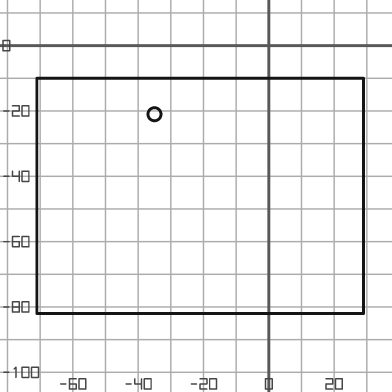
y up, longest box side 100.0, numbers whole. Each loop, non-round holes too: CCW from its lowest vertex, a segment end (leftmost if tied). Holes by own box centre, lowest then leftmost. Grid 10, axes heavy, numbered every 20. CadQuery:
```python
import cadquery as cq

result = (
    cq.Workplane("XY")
    .moveTo(-71.0, -82.0)
    .lineTo(29.0, -82.0)
    .lineTo(29.0, -10.0)
    .lineTo(-71.0, -10.0)
    .close()
    .moveTo(-35.0, -21.0)
    .circle(2.0)
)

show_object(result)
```